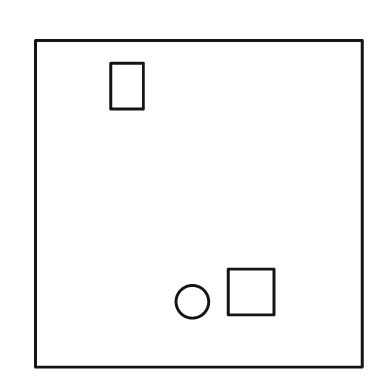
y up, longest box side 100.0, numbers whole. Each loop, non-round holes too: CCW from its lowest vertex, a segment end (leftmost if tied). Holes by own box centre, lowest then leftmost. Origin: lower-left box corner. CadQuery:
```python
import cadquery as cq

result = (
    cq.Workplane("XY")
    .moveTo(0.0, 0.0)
    .lineTo(100.0, 0.0)
    .lineTo(100.0, 100.0)
    .lineTo(0.0, 100.0)
    .close()
    .moveTo(48.0, 20.0)
    .circle(5.0)
    .moveTo(59.0, 16.0)
    .lineTo(73.0, 16.0)
    .lineTo(73.0, 30.0)
    .lineTo(59.0, 30.0)
    .close()
    .moveTo(23.0, 79.0)
    .lineTo(33.0, 79.0)
    .lineTo(33.0, 93.0)
    .lineTo(23.0, 93.0)
    .close()
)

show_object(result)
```